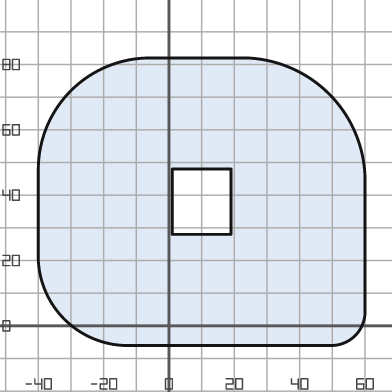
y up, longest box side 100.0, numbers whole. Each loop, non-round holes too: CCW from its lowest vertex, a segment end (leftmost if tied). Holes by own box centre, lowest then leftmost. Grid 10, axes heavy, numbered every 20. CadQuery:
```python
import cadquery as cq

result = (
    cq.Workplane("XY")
    .moveTo(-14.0, -6.0)
    .lineTo(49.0, -6.0)
    .threePointArc((57.0, -3.0), (60.0, 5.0))
    .lineTo(60.0, 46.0)
    .threePointArc((49.0, 71.0), (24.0, 82.0))
    .lineTo(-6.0, 82.0)
    .threePointArc((-30.0, 72.0), (-40.0, 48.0))
    .lineTo(-40.0, 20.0)
    .threePointArc((-32.0, 2.0), (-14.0, -6.0))
    .close()
    .moveTo(1.0, 28.0)
    .lineTo(19.0, 28.0)
    .lineTo(19.0, 48.0)
    .lineTo(1.0, 48.0)
    .close()
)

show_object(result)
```